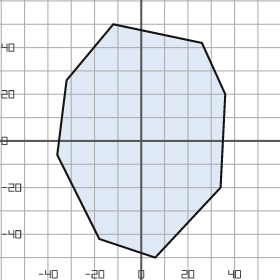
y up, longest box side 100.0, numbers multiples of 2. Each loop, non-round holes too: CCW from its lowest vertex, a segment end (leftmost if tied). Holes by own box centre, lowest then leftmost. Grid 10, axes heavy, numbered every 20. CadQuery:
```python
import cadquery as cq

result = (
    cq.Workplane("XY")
    .moveTo(6.0, -50.0)
    .lineTo(34.0, -20.0)
    .lineTo(36.0, 20.0)
    .lineTo(26.0, 42.0)
    .lineTo(-12.0, 50.0)
    .lineTo(-32.0, 26.0)
    .lineTo(-36.0, -6.0)
    .lineTo(-18.0, -42.0)
    .close()
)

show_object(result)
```